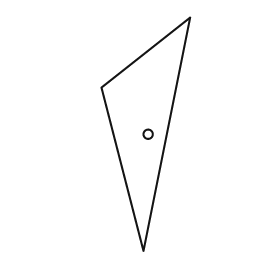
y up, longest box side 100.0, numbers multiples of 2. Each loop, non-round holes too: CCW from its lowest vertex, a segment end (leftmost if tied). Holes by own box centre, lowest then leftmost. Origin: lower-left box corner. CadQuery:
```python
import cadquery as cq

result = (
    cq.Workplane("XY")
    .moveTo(18.0, 0.0)
    .lineTo(38.0, 100.0)
    .lineTo(0.0, 70.0)
    .close()
    .moveTo(20.0, 50.0)
    .circle(2.0)
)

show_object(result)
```